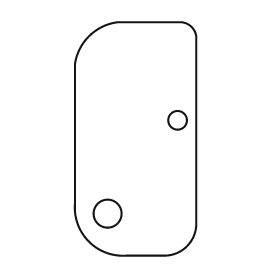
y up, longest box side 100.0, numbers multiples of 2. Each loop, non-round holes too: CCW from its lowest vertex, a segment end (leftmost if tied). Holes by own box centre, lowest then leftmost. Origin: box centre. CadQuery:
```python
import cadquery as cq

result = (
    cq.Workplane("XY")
    .moveTo(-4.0, -50.0)
    .lineTo(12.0, -50.0)
    .threePointArc((22.0, -46.0), (26.0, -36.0))
    .lineTo(26.0, 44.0)
    .threePointArc((24.0, 48.0), (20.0, 50.0))
    .lineTo(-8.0, 50.0)
    .threePointArc((-20.0, 44.0), (-26.0, 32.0))
    .lineTo(-26.0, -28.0)
    .threePointArc((-20.0, -44.0), (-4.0, -50.0))
    .close()
    .moveTo(-12.0, -32.0)
    .circle(6.0)
    .moveTo(18.0, 8.0)
    .circle(4.0)
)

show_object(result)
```